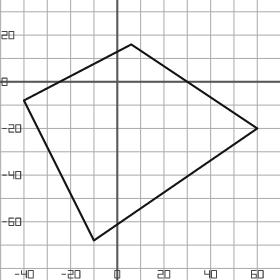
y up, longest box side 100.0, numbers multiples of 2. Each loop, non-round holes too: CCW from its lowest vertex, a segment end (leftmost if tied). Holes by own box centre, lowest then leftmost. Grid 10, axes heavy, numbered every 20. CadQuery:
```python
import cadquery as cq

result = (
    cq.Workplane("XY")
    .moveTo(-10.0, -68.0)
    .lineTo(60.0, -20.0)
    .lineTo(6.0, 16.0)
    .lineTo(-40.0, -8.0)
    .close()
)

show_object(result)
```